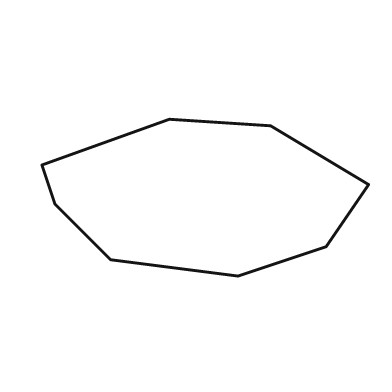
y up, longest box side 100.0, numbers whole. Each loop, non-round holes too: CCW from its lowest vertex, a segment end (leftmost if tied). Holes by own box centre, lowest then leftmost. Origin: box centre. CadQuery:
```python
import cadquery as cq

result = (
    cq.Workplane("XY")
    .moveTo(10.0, -24.0)
    .lineTo(37.0, -15.0)
    .lineTo(50.0, 4.0)
    .lineTo(20.0, 22.0)
    .lineTo(-11.0, 24.0)
    .lineTo(-50.0, 10.0)
    .lineTo(-46.0, -2.0)
    .lineTo(-29.0, -19.0)
    .close()
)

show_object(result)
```